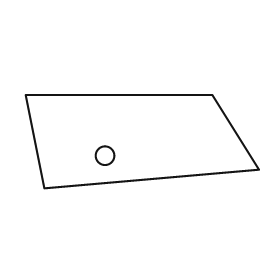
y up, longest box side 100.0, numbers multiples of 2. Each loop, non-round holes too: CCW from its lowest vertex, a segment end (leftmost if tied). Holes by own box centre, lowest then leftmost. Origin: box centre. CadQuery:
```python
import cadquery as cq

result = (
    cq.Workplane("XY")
    .moveTo(-42.0, -20.0)
    .lineTo(50.0, -12.0)
    .lineTo(30.0, 20.0)
    .lineTo(-50.0, 20.0)
    .close()
    .moveTo(-16.0, -6.0)
    .circle(4.0)
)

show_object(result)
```